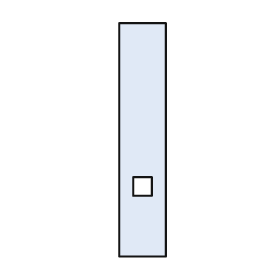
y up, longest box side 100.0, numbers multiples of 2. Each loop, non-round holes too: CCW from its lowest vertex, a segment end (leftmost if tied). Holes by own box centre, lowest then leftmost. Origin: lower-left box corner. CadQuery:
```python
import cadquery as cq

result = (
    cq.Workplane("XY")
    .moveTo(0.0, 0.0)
    .lineTo(20.0, 0.0)
    .lineTo(20.0, 100.0)
    .lineTo(0.0, 100.0)
    .close()
    .moveTo(6.0, 26.0)
    .lineTo(14.0, 26.0)
    .lineTo(14.0, 34.0)
    .lineTo(6.0, 34.0)
    .close()
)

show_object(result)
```